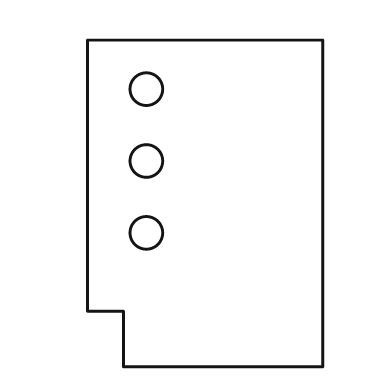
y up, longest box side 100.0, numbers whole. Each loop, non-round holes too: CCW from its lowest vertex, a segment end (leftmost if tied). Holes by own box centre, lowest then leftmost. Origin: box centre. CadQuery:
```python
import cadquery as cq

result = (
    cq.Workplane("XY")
    .moveTo(-25.0, -50.0)
    .lineTo(36.0, -50.0)
    .lineTo(36.0, 50.0)
    .lineTo(-36.0, 50.0)
    .lineTo(-36.0, -33.0)
    .lineTo(-25.0, -33.0)
    .close()
    .moveTo(-18.0, -9.0)
    .circle(5.0)
    .moveTo(-18.0, 13.0)
    .circle(5.0)
    .moveTo(-18.0, 35.0)
    .circle(5.0)
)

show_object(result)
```